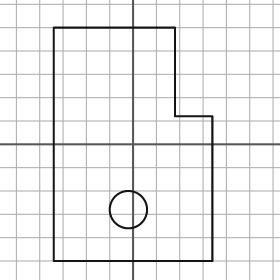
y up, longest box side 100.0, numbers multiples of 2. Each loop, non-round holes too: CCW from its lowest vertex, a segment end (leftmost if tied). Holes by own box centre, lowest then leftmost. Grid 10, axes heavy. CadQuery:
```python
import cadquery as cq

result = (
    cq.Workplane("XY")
    .moveTo(-34.0, -50.0)
    .lineTo(34.0, -50.0)
    .lineTo(34.0, 12.0)
    .lineTo(18.0, 12.0)
    .lineTo(18.0, 50.0)
    .lineTo(-34.0, 50.0)
    .close()
    .moveTo(-2.0, -28.0)
    .circle(8.0)
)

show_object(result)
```